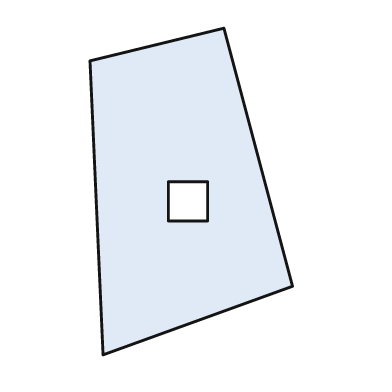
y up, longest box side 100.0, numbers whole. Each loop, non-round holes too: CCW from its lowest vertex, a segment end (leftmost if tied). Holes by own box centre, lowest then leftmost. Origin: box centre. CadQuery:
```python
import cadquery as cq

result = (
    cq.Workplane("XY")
    .moveTo(-27.0, -50.0)
    .lineTo(31.0, -29.0)
    .lineTo(10.0, 50.0)
    .lineTo(-31.0, 40.0)
    .close()
    .moveTo(-7.0, -9.0)
    .lineTo(5.0, -9.0)
    .lineTo(5.0, 3.0)
    .lineTo(-7.0, 3.0)
    .close()
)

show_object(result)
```